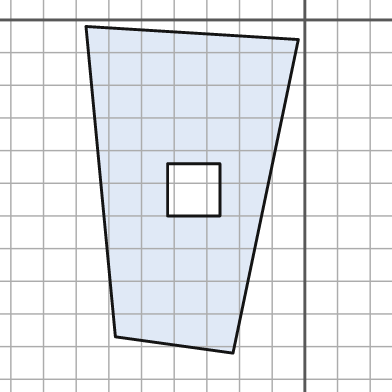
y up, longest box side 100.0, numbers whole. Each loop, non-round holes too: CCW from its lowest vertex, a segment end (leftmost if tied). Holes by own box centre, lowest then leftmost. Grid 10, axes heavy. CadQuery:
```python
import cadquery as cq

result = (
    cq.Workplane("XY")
    .moveTo(-22.0, -102.0)
    .lineTo(-2.0, -6.0)
    .lineTo(-67.0, -2.0)
    .lineTo(-58.0, -97.0)
    .close()
    .moveTo(-42.0, -60.0)
    .lineTo(-26.0, -60.0)
    .lineTo(-26.0, -44.0)
    .lineTo(-42.0, -44.0)
    .close()
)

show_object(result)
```